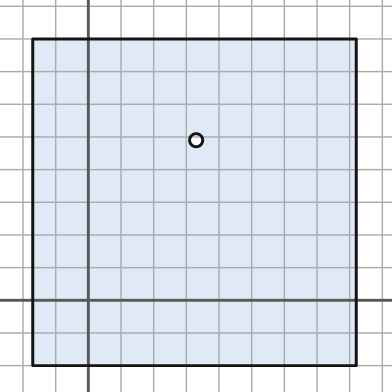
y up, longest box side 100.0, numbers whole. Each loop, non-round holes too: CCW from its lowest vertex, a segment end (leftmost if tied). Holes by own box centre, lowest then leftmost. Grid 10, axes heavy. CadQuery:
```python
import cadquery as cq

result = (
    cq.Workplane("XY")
    .moveTo(-17.0, -20.0)
    .lineTo(82.0, -20.0)
    .lineTo(82.0, 80.0)
    .lineTo(-17.0, 80.0)
    .close()
    .moveTo(33.0, 49.0)
    .circle(2.0)
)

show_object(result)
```